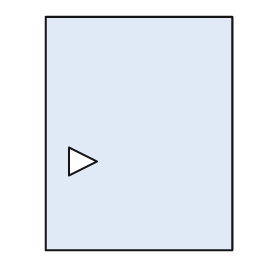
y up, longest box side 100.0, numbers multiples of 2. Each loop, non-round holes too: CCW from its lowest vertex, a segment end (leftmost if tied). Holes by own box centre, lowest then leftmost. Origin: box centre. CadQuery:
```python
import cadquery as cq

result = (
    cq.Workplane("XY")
    .moveTo(-40.0, -50.0)
    .lineTo(40.0, -50.0)
    .lineTo(40.0, 50.0)
    .lineTo(-40.0, 50.0)
    .close()
    .moveTo(-30.0, -18.0)
    .lineTo(-18.0, -12.0)
    .lineTo(-30.0, -6.0)
    .close()
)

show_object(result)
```